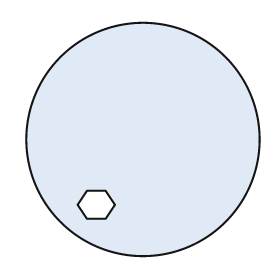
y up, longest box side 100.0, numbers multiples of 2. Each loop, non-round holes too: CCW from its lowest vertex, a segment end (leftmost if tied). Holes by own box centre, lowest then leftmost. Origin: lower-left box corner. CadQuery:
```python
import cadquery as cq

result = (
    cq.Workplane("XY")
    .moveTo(50.0, 50.0)
    .circle(50.0)
    .moveTo(26.0, 16.0)
    .lineTo(34.0, 16.0)
    .lineTo(38.0, 22.0)
    .lineTo(34.0, 28.0)
    .lineTo(26.0, 28.0)
    .lineTo(22.0, 22.0)
    .close()
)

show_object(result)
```